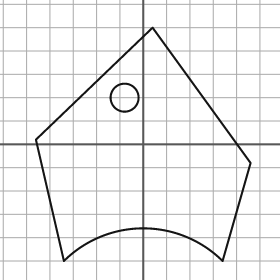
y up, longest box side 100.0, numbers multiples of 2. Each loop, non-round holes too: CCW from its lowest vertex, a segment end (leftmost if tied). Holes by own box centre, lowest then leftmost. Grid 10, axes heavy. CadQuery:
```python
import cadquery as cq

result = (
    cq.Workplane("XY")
    .moveTo(-34.0, -50.0)
    .threePointArc((0.0, -36.0), (34.0, -50.0))
    .lineTo(46.0, -8.0)
    .lineTo(4.0, 50.0)
    .lineTo(-46.0, 2.0)
    .close()
    .moveTo(-8.0, 20.0)
    .circle(6.0)
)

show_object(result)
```